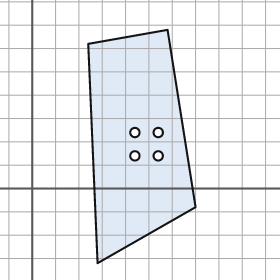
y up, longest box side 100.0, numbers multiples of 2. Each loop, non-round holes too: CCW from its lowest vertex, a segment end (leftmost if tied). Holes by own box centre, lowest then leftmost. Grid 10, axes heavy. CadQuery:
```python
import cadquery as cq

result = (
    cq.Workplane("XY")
    .moveTo(28.0, -32.0)
    .lineTo(70.0, -8.0)
    .lineTo(58.0, 68.0)
    .lineTo(24.0, 62.0)
    .close()
    .moveTo(44.0, 14.0)
    .circle(2.0)
    .moveTo(54.0, 14.0)
    .circle(2.0)
    .moveTo(44.0, 24.0)
    .circle(2.0)
    .moveTo(54.0, 24.0)
    .circle(2.0)
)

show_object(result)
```